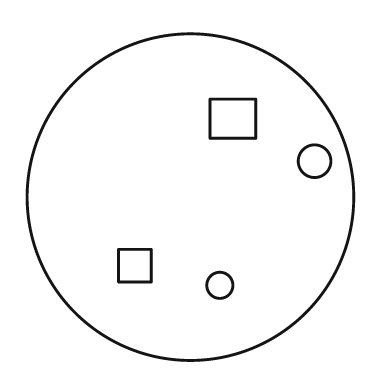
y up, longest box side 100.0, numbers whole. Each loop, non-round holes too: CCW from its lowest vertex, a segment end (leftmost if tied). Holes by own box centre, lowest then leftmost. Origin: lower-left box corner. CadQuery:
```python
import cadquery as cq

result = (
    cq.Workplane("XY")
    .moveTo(50.0, 50.0)
    .circle(50.0)
    .moveTo(59.0, 23.0)
    .circle(4.0)
    .moveTo(28.0, 24.0)
    .lineTo(38.0, 24.0)
    .lineTo(38.0, 34.0)
    .lineTo(28.0, 34.0)
    .close()
    .moveTo(88.0, 61.0)
    .circle(5.0)
    .moveTo(56.0, 68.0)
    .lineTo(70.0, 68.0)
    .lineTo(70.0, 80.0)
    .lineTo(56.0, 80.0)
    .close()
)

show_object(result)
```